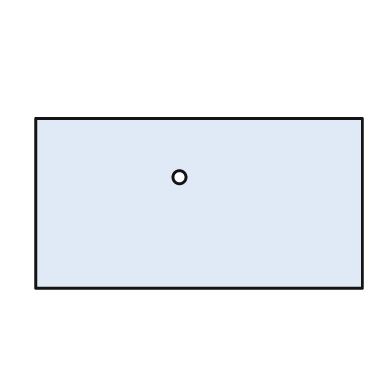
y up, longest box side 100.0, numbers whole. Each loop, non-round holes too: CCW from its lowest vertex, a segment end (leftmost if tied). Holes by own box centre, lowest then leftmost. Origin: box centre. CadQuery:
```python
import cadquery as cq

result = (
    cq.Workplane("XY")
    .moveTo(-50.0, -26.0)
    .lineTo(50.0, -26.0)
    .lineTo(50.0, 26.0)
    .lineTo(-50.0, 26.0)
    .close()
    .moveTo(-6.0, 8.0)
    .circle(2.0)
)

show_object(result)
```